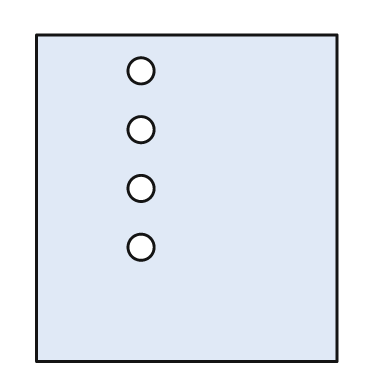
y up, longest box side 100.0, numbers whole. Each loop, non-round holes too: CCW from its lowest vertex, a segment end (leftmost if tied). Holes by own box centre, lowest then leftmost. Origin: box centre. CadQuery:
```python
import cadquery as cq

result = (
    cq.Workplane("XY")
    .moveTo(-46.0, -50.0)
    .lineTo(46.0, -50.0)
    .lineTo(46.0, 50.0)
    .lineTo(-46.0, 50.0)
    .close()
    .moveTo(-14.0, -15.0)
    .circle(4.0)
    .moveTo(-14.0, 3.0)
    .circle(4.0)
    .moveTo(-14.0, 21.0)
    .circle(4.0)
    .moveTo(-14.0, 39.0)
    .circle(4.0)
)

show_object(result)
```